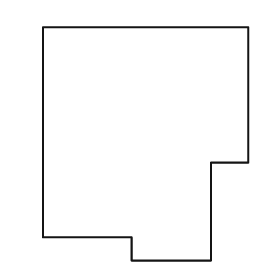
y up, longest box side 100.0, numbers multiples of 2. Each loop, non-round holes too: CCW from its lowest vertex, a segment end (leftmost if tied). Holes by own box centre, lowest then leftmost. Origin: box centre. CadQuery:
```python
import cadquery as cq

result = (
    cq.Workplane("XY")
    .moveTo(-6.0, -50.0)
    .lineTo(28.0, -50.0)
    .lineTo(28.0, -8.0)
    .lineTo(44.0, -8.0)
    .lineTo(44.0, 50.0)
    .lineTo(-44.0, 50.0)
    .lineTo(-44.0, -40.0)
    .lineTo(-6.0, -40.0)
    .close()
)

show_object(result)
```